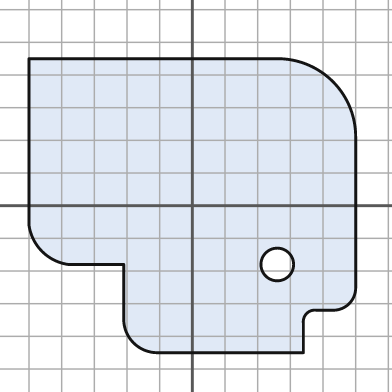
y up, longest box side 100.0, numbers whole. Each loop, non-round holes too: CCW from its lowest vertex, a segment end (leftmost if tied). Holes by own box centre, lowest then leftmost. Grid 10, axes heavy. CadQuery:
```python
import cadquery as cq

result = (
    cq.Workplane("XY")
    .moveTo(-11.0, -45.0)
    .lineTo(34.0, -45.0)
    .lineTo(34.0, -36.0)
    .threePointArc((35.0, -33.0), (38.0, -32.0))
    .lineTo(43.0, -32.0)
    .threePointArc((48.0, -30.0), (50.0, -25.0))
    .lineTo(50.0, 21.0)
    .threePointArc((43.0, 38.0), (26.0, 45.0))
    .lineTo(-50.0, 45.0)
    .lineTo(-50.0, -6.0)
    .threePointArc((-46.0, -14.0), (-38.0, -18.0))
    .lineTo(-21.0, -18.0)
    .lineTo(-21.0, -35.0)
    .threePointArc((-18.0, -42.0), (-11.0, -45.0))
    .close()
    .moveTo(26.0, -18.0)
    .circle(5.0)
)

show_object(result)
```